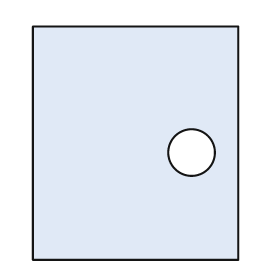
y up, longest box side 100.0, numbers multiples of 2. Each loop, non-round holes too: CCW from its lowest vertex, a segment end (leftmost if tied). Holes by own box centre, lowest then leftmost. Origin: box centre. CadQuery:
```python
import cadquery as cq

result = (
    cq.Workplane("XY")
    .moveTo(-44.0, -50.0)
    .lineTo(44.0, -50.0)
    .lineTo(44.0, 50.0)
    .lineTo(-44.0, 50.0)
    .close()
    .moveTo(24.0, -4.0)
    .circle(10.0)
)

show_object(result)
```